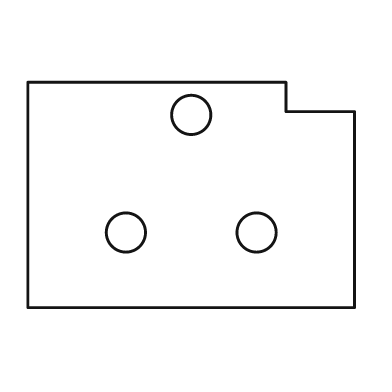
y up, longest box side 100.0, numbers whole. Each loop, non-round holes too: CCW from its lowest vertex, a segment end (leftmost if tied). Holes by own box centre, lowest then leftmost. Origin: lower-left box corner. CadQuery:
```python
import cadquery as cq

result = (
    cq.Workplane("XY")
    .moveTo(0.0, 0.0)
    .lineTo(100.0, 0.0)
    .lineTo(100.0, 60.0)
    .lineTo(79.0, 60.0)
    .lineTo(79.0, 69.0)
    .lineTo(0.0, 69.0)
    .close()
    .moveTo(30.0, 23.0)
    .circle(6.0)
    .moveTo(70.0, 23.0)
    .circle(6.0)
    .moveTo(50.0, 59.0)
    .circle(6.0)
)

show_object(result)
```